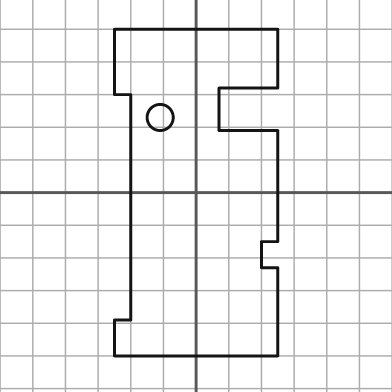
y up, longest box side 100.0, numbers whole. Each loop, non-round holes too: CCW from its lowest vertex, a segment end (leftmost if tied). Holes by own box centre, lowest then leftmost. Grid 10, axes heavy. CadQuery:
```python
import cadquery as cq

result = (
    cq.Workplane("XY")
    .moveTo(-25.0, -50.0)
    .lineTo(25.0, -50.0)
    .lineTo(25.0, -23.0)
    .lineTo(20.0, -23.0)
    .lineTo(20.0, -15.0)
    .lineTo(25.0, -15.0)
    .lineTo(25.0, 19.0)
    .lineTo(7.0, 19.0)
    .lineTo(7.0, 32.0)
    .lineTo(25.0, 32.0)
    .lineTo(25.0, 50.0)
    .lineTo(-25.0, 50.0)
    .lineTo(-25.0, 30.0)
    .lineTo(-20.0, 30.0)
    .lineTo(-20.0, -39.0)
    .lineTo(-25.0, -39.0)
    .close()
    .moveTo(-11.0, 23.0)
    .circle(4.0)
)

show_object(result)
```